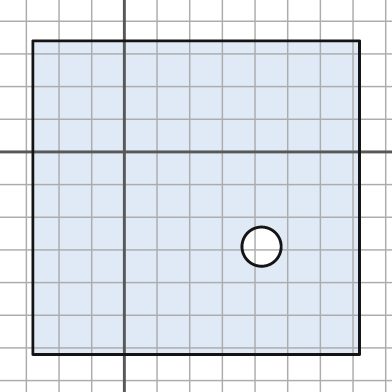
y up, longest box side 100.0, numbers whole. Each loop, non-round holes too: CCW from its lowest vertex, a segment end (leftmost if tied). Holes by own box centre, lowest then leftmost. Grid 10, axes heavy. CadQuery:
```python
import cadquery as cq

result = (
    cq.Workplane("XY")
    .moveTo(-28.0, -62.0)
    .lineTo(72.0, -62.0)
    .lineTo(72.0, 34.0)
    .lineTo(-28.0, 34.0)
    .close()
    .moveTo(42.0, -29.0)
    .circle(6.0)
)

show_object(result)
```